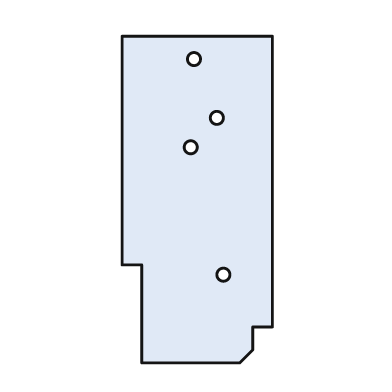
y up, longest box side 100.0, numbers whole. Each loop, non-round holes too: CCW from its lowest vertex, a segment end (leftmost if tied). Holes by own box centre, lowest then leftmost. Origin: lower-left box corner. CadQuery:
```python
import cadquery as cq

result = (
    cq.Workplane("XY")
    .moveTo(6.0, 0.0)
    .lineTo(36.0, 0.0)
    .lineTo(40.0, 4.0)
    .lineTo(40.0, 11.0)
    .lineTo(46.0, 11.0)
    .lineTo(46.0, 100.0)
    .lineTo(0.0, 100.0)
    .lineTo(0.0, 30.0)
    .lineTo(6.0, 30.0)
    .close()
    .moveTo(31.0, 27.0)
    .circle(2.0)
    .moveTo(21.0, 66.0)
    .circle(2.0)
    .moveTo(29.0, 75.0)
    .circle(2.0)
    .moveTo(22.0, 93.0)
    .circle(2.0)
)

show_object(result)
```